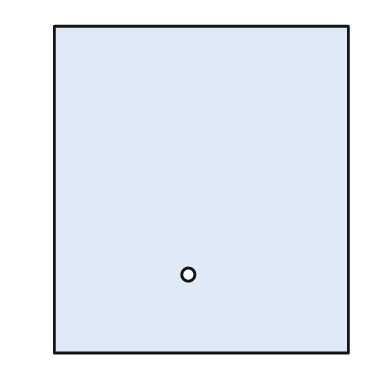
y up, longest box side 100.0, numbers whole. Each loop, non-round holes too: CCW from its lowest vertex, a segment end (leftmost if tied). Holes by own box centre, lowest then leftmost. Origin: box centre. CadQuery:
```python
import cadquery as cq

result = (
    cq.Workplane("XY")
    .moveTo(-45.0, -50.0)
    .lineTo(45.0, -50.0)
    .lineTo(45.0, 50.0)
    .lineTo(-45.0, 50.0)
    .close()
    .moveTo(-4.0, -26.0)
    .circle(2.0)
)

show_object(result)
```